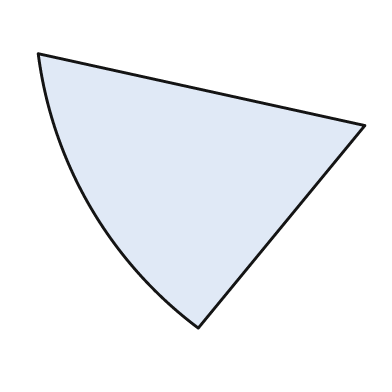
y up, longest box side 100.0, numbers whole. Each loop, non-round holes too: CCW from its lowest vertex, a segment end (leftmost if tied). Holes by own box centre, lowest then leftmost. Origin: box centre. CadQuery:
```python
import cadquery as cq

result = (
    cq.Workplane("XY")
    .moveTo(-1.0, -42.0)
    .lineTo(50.0, 20.0)
    .lineTo(-50.0, 42.0)
    .threePointArc((-34.0, -5.0), (-1.0, -42.0))
    .close()
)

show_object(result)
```